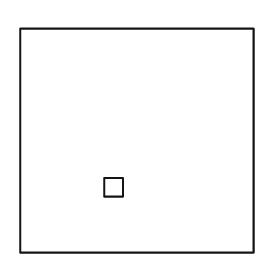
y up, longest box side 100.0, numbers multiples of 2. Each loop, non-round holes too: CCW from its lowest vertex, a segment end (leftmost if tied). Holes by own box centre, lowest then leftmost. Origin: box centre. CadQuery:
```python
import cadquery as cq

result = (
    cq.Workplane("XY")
    .moveTo(-50.0, -48.0)
    .lineTo(50.0, -48.0)
    .lineTo(50.0, 48.0)
    .lineTo(-50.0, 48.0)
    .close()
    .moveTo(-14.0, -24.0)
    .lineTo(-6.0, -24.0)
    .lineTo(-6.0, -16.0)
    .lineTo(-14.0, -16.0)
    .close()
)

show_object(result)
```